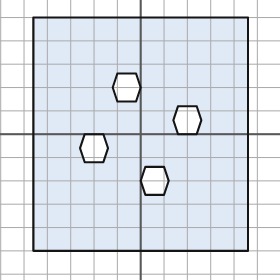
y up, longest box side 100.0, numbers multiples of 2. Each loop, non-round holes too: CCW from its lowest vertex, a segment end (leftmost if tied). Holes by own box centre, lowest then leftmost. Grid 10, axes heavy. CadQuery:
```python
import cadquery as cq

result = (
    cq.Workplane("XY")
    .moveTo(-46.0, -50.0)
    .lineTo(46.0, -50.0)
    .lineTo(46.0, 50.0)
    .lineTo(-46.0, 50.0)
    .close()
    .moveTo(2.0, -26.0)
    .lineTo(10.0, -26.0)
    .lineTo(12.0, -20.0)
    .lineTo(10.0, -14.0)
    .lineTo(2.0, -14.0)
    .lineTo(0.0, -20.0)
    .close()
    .moveTo(-24.0, -12.0)
    .lineTo(-16.0, -12.0)
    .lineTo(-14.0, -6.0)
    .lineTo(-16.0, 0.0)
    .lineTo(-24.0, 0.0)
    .lineTo(-26.0, -6.0)
    .close()
    .moveTo(16.0, 0.0)
    .lineTo(24.0, 0.0)
    .lineTo(26.0, 6.0)
    .lineTo(24.0, 12.0)
    .lineTo(16.0, 12.0)
    .lineTo(14.0, 6.0)
    .close()
    .moveTo(-10.0, 14.0)
    .lineTo(-2.0, 14.0)
    .lineTo(0.0, 20.0)
    .lineTo(-2.0, 26.0)
    .lineTo(-10.0, 26.0)
    .lineTo(-12.0, 20.0)
    .close()
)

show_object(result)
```